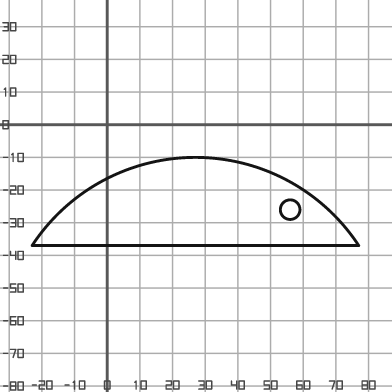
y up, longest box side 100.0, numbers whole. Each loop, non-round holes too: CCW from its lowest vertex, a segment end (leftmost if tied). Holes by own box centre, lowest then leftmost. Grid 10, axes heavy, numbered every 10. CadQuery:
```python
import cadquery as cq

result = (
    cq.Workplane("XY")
    .moveTo(-23.0, -37.0)
    .lineTo(77.0, -37.0)
    .threePointArc((27.0, -10.0), (-23.0, -37.0))
    .close()
    .moveTo(56.0, -26.0)
    .circle(3.0)
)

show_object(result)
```